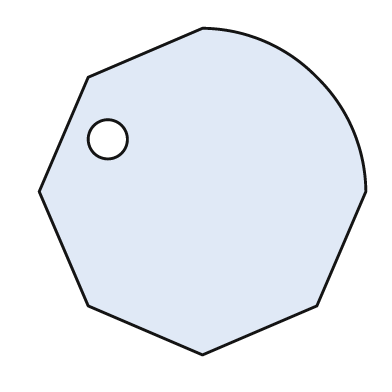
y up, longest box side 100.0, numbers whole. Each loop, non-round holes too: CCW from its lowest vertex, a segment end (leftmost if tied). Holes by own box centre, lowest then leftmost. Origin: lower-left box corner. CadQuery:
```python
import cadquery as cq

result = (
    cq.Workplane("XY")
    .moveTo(50.0, 0.0)
    .lineTo(85.0, 15.0)
    .lineTo(100.0, 50.0)
    .threePointArc((96.0, 69.0), (85.0, 85.0))
    .threePointArc((69.0, 96.0), (50.0, 100.0))
    .lineTo(15.0, 85.0)
    .lineTo(0.0, 50.0)
    .lineTo(15.0, 15.0)
    .close()
    .moveTo(21.0, 66.0)
    .circle(6.0)
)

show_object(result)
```